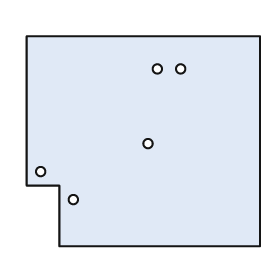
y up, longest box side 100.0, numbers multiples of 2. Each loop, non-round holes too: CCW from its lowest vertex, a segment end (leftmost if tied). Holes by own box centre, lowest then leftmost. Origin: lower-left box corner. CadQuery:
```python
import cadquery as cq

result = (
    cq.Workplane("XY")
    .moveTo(14.0, 0.0)
    .lineTo(100.0, 0.0)
    .lineTo(100.0, 90.0)
    .lineTo(0.0, 90.0)
    .lineTo(0.0, 26.0)
    .lineTo(14.0, 26.0)
    .close()
    .moveTo(20.0, 20.0)
    .circle(2.0)
    .moveTo(6.0, 32.0)
    .circle(2.0)
    .moveTo(52.0, 44.0)
    .circle(2.0)
    .moveTo(56.0, 76.0)
    .circle(2.0)
    .moveTo(66.0, 76.0)
    .circle(2.0)
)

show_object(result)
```